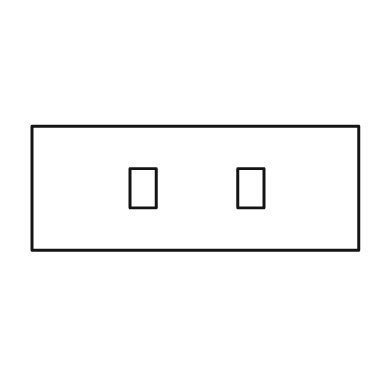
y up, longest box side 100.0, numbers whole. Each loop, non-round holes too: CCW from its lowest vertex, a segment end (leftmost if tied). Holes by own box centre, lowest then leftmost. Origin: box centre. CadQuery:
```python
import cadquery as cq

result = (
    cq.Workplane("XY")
    .moveTo(-50.0, -19.0)
    .lineTo(50.0, -19.0)
    .lineTo(50.0, 19.0)
    .lineTo(-50.0, 19.0)
    .close()
    .moveTo(-20.0, -6.0)
    .lineTo(-12.0, -6.0)
    .lineTo(-12.0, 6.0)
    .lineTo(-20.0, 6.0)
    .close()
    .moveTo(13.0, -6.0)
    .lineTo(21.0, -6.0)
    .lineTo(21.0, 6.0)
    .lineTo(13.0, 6.0)
    .close()
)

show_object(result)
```